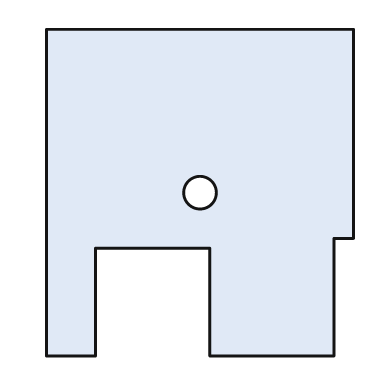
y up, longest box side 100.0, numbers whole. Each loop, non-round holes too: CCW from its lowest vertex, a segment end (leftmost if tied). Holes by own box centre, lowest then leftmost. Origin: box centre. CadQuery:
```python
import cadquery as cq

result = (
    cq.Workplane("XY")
    .moveTo(-47.0, -50.0)
    .lineTo(-32.0, -50.0)
    .lineTo(-32.0, -17.0)
    .lineTo(3.0, -17.0)
    .lineTo(3.0, -50.0)
    .lineTo(41.0, -50.0)
    .lineTo(41.0, -14.0)
    .lineTo(47.0, -14.0)
    .lineTo(47.0, 50.0)
    .lineTo(-47.0, 50.0)
    .close()
    .moveTo(0.0, 0.0)
    .circle(5.0)
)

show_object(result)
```